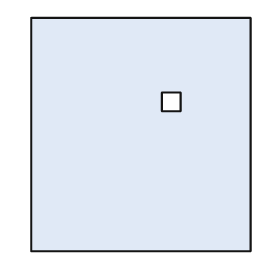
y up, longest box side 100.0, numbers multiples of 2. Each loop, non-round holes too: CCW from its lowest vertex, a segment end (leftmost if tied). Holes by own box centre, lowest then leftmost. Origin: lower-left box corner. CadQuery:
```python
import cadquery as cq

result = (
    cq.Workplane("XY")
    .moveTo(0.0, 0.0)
    .lineTo(94.0, 0.0)
    .lineTo(94.0, 100.0)
    .lineTo(0.0, 100.0)
    .close()
    .moveTo(56.0, 60.0)
    .lineTo(64.0, 60.0)
    .lineTo(64.0, 68.0)
    .lineTo(56.0, 68.0)
    .close()
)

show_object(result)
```